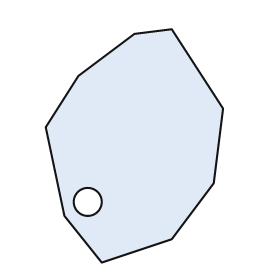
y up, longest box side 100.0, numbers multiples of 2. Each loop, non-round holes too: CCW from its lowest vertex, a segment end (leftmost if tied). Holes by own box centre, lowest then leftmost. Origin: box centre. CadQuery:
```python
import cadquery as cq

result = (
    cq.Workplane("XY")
    .moveTo(-14.0, -50.0)
    .lineTo(16.0, -40.0)
    .lineTo(34.0, -16.0)
    .lineTo(38.0, 16.0)
    .lineTo(16.0, 50.0)
    .lineTo(0.0, 48.0)
    .lineTo(-24.0, 30.0)
    .lineTo(-38.0, 8.0)
    .lineTo(-30.0, -30.0)
    .close()
    .moveTo(-20.0, -24.0)
    .circle(6.0)
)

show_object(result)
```